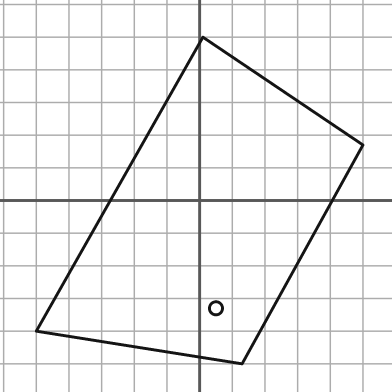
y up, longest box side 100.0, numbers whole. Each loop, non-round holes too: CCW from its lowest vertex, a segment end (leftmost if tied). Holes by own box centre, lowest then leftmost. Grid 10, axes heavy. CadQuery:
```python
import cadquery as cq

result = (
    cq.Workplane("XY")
    .moveTo(13.0, -50.0)
    .lineTo(50.0, 17.0)
    .lineTo(1.0, 50.0)
    .lineTo(-50.0, -40.0)
    .close()
    .moveTo(5.0, -33.0)
    .circle(2.0)
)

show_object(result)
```